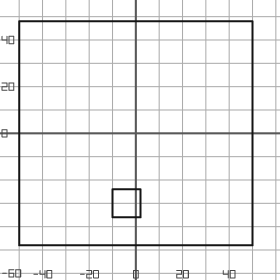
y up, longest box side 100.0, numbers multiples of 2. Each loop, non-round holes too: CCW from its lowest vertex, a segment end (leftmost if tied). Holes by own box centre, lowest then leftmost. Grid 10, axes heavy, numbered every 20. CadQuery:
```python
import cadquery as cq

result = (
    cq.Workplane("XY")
    .moveTo(-50.0, -48.0)
    .lineTo(50.0, -48.0)
    .lineTo(50.0, 48.0)
    .lineTo(-50.0, 48.0)
    .close()
    .moveTo(-10.0, -36.0)
    .lineTo(2.0, -36.0)
    .lineTo(2.0, -24.0)
    .lineTo(-10.0, -24.0)
    .close()
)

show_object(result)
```